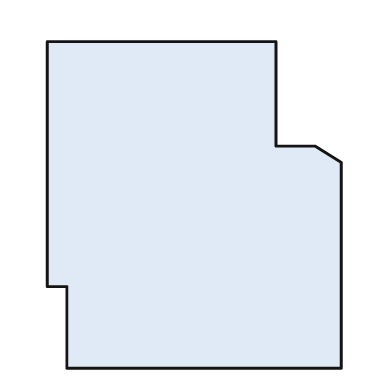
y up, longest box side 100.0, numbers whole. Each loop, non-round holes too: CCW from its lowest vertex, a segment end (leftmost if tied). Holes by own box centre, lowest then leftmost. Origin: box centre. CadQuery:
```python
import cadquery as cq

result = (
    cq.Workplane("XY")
    .moveTo(-39.0, -50.0)
    .lineTo(45.0, -50.0)
    .lineTo(45.0, 13.0)
    .lineTo(37.0, 18.0)
    .lineTo(25.0, 18.0)
    .lineTo(25.0, 50.0)
    .lineTo(-45.0, 50.0)
    .lineTo(-45.0, -25.0)
    .lineTo(-39.0, -25.0)
    .close()
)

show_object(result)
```